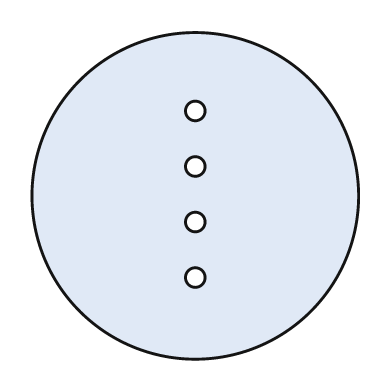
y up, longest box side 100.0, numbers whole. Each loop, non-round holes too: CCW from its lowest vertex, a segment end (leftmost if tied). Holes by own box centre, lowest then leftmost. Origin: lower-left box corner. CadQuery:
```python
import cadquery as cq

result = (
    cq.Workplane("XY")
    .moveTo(50.0, 50.0)
    .circle(50.0)
    .moveTo(50.0, 25.0)
    .circle(3.0)
    .moveTo(50.0, 42.0)
    .circle(3.0)
    .moveTo(50.0, 59.0)
    .circle(3.0)
    .moveTo(50.0, 76.0)
    .circle(3.0)
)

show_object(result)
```